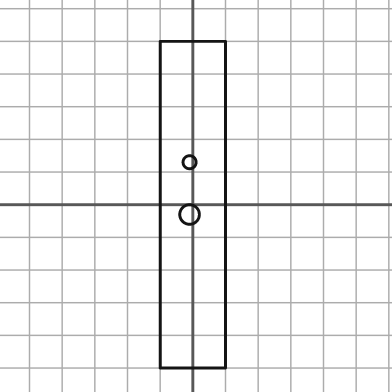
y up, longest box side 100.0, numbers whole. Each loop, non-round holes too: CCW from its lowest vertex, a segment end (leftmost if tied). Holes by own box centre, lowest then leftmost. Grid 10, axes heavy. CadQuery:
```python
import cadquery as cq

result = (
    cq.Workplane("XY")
    .moveTo(-10.0, -50.0)
    .lineTo(10.0, -50.0)
    .lineTo(10.0, 50.0)
    .lineTo(-10.0, 50.0)
    .close()
    .moveTo(-1.0, -3.0)
    .circle(3.0)
    .moveTo(-1.0, 13.0)
    .circle(2.0)
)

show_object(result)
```